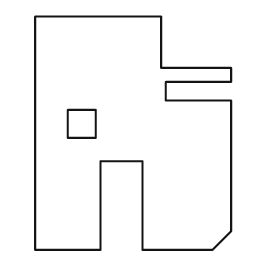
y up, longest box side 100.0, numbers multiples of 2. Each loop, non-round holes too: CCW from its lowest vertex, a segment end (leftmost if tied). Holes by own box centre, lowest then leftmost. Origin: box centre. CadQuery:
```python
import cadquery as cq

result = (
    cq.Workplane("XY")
    .moveTo(-42.0, -50.0)
    .lineTo(-14.0, -50.0)
    .lineTo(-14.0, -12.0)
    .lineTo(4.0, -12.0)
    .lineTo(4.0, -50.0)
    .lineTo(34.0, -50.0)
    .lineTo(42.0, -42.0)
    .lineTo(42.0, 14.0)
    .lineTo(14.0, 14.0)
    .lineTo(14.0, 22.0)
    .lineTo(42.0, 22.0)
    .lineTo(42.0, 28.0)
    .lineTo(12.0, 28.0)
    .lineTo(12.0, 50.0)
    .lineTo(-42.0, 50.0)
    .close()
    .moveTo(-28.0, -2.0)
    .lineTo(-16.0, -2.0)
    .lineTo(-16.0, 10.0)
    .lineTo(-28.0, 10.0)
    .close()
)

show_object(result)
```